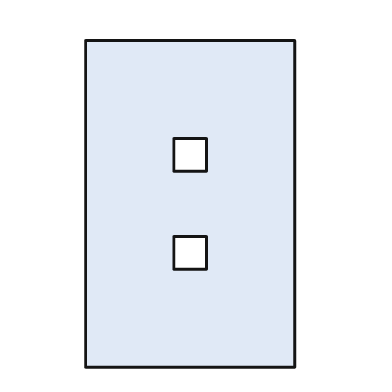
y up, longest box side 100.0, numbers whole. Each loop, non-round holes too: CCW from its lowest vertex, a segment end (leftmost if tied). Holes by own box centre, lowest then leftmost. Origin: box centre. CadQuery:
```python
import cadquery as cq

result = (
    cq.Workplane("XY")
    .moveTo(-32.0, -50.0)
    .lineTo(32.0, -50.0)
    .lineTo(32.0, 50.0)
    .lineTo(-32.0, 50.0)
    .close()
    .moveTo(-5.0, -20.0)
    .lineTo(5.0, -20.0)
    .lineTo(5.0, -10.0)
    .lineTo(-5.0, -10.0)
    .close()
    .moveTo(-5.0, 10.0)
    .lineTo(5.0, 10.0)
    .lineTo(5.0, 20.0)
    .lineTo(-5.0, 20.0)
    .close()
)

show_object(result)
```